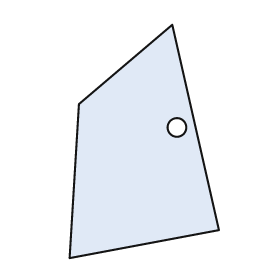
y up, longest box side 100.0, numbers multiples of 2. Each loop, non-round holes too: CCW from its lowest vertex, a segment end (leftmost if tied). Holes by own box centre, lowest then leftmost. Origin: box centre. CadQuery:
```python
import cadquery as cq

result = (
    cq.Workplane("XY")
    .moveTo(-32.0, -50.0)
    .lineTo(32.0, -38.0)
    .lineTo(12.0, 50.0)
    .lineTo(-28.0, 16.0)
    .close()
    .moveTo(14.0, 6.0)
    .circle(4.0)
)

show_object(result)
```